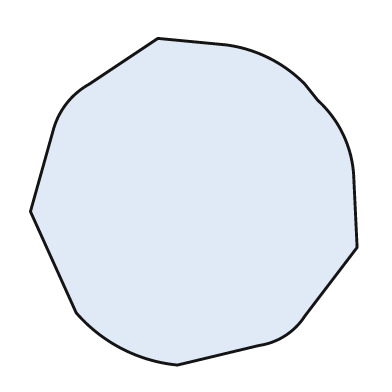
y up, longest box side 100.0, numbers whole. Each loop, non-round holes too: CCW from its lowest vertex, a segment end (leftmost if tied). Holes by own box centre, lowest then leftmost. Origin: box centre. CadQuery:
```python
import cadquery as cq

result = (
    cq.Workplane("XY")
    .moveTo(-5.0, -50.0)
    .lineTo(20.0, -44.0)
    .threePointArc((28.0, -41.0), (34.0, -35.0))
    .lineTo(50.0, -14.0)
    .lineTo(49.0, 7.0)
    .threePointArc((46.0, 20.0), (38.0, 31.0))
    .lineTo(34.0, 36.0)
    .threePointArc((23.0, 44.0), (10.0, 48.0))
    .lineTo(-11.0, 50.0)
    .lineTo(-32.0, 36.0)
    .threePointArc((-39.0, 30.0), (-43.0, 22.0))
    .lineTo(-50.0, -3.0)
    .lineTo(-36.0, -34.0)
    .threePointArc((-22.0, -45.0), (-5.0, -50.0))
    .close()
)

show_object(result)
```